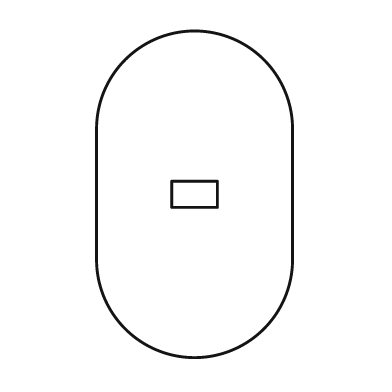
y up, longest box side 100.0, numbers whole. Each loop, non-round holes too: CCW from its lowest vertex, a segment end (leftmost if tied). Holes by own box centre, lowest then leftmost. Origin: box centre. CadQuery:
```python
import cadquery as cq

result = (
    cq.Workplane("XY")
    .moveTo(-30.0, -20.0)
    .threePointArc((0.0, -50.0), (30.0, -20.0))
    .lineTo(30.0, 20.0)
    .threePointArc((0.0, 50.0), (-30.0, 20.0))
    .close()
    .moveTo(-7.0, -4.0)
    .lineTo(7.0, -4.0)
    .lineTo(7.0, 4.0)
    .lineTo(-7.0, 4.0)
    .close()
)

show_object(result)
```